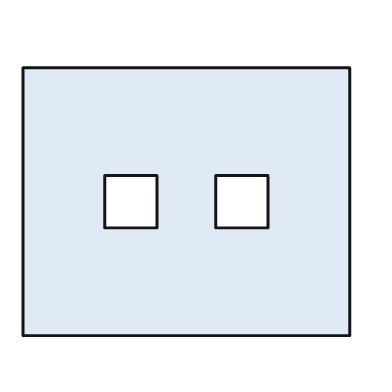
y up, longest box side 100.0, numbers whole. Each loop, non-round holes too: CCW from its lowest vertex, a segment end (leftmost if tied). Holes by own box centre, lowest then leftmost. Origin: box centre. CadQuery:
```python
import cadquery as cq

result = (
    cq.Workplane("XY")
    .moveTo(-50.0, -41.0)
    .lineTo(50.0, -41.0)
    .lineTo(50.0, 41.0)
    .lineTo(-50.0, 41.0)
    .close()
    .moveTo(-25.0, -8.0)
    .lineTo(-9.0, -8.0)
    .lineTo(-9.0, 8.0)
    .lineTo(-25.0, 8.0)
    .close()
    .moveTo(9.0, -8.0)
    .lineTo(25.0, -8.0)
    .lineTo(25.0, 8.0)
    .lineTo(9.0, 8.0)
    .close()
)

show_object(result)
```